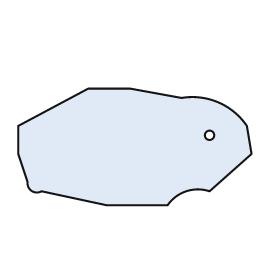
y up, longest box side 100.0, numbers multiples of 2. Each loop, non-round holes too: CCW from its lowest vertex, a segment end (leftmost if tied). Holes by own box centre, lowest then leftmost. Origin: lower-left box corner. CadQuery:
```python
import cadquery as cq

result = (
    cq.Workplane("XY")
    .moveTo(38.0, 0.0)
    .lineTo(64.0, 0.0)
    .threePointArc((72.0, 6.0), (82.0, 6.0))
    .lineTo(100.0, 22.0)
    .lineTo(98.0, 34.0)
    .threePointArc((86.0, 44.0), (70.0, 46.0))
    .lineTo(48.0, 50.0)
    .lineTo(30.0, 50.0)
    .lineTo(0.0, 34.0)
    .lineTo(0.0, 22.0)
    .lineTo(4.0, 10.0)
    .threePointArc((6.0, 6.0), (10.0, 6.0))
    .close()
    .moveTo(82.0, 30.0)
    .circle(2.0)
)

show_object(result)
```